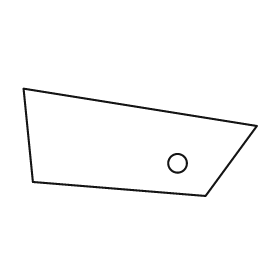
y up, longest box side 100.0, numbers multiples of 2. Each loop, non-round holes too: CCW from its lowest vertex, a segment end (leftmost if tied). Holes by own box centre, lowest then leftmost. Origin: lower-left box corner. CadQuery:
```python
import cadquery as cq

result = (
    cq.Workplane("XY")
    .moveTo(78.0, 0.0)
    .lineTo(100.0, 30.0)
    .lineTo(0.0, 46.0)
    .lineTo(4.0, 6.0)
    .close()
    .moveTo(66.0, 14.0)
    .circle(4.0)
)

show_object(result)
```